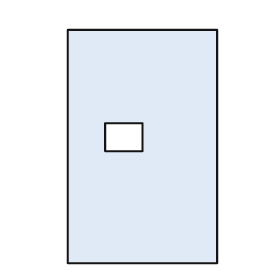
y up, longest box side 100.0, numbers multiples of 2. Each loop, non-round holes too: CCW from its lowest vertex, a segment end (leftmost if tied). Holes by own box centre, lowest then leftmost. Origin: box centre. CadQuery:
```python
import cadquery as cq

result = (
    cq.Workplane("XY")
    .moveTo(-32.0, -50.0)
    .lineTo(32.0, -50.0)
    .lineTo(32.0, 50.0)
    .lineTo(-32.0, 50.0)
    .close()
    .moveTo(-16.0, -2.0)
    .lineTo(0.0, -2.0)
    .lineTo(0.0, 10.0)
    .lineTo(-16.0, 10.0)
    .close()
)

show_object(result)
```